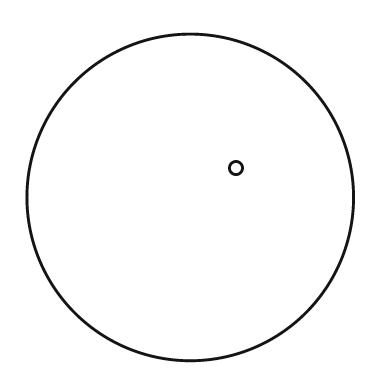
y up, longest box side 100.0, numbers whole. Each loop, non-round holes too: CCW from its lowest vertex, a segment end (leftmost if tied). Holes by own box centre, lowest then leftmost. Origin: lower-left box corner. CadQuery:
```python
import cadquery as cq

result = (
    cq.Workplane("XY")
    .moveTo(50.0, 50.0)
    .circle(50.0)
    .moveTo(64.0, 59.0)
    .circle(2.0)
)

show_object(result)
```